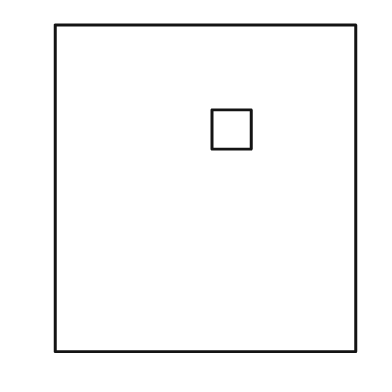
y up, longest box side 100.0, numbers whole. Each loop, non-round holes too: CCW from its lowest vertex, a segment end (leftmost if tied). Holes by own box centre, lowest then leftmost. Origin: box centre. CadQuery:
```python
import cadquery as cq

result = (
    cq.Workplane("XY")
    .moveTo(-46.0, -50.0)
    .lineTo(46.0, -50.0)
    .lineTo(46.0, 50.0)
    .lineTo(-46.0, 50.0)
    .close()
    .moveTo(2.0, 12.0)
    .lineTo(14.0, 12.0)
    .lineTo(14.0, 24.0)
    .lineTo(2.0, 24.0)
    .close()
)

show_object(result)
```